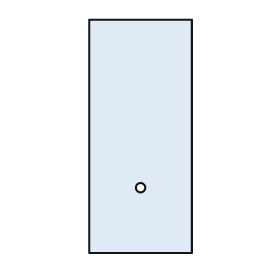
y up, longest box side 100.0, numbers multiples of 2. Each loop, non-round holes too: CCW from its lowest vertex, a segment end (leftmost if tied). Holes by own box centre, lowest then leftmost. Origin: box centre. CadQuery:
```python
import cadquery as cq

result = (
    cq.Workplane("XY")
    .moveTo(-22.0, -50.0)
    .lineTo(22.0, -50.0)
    .lineTo(22.0, 50.0)
    .lineTo(-22.0, 50.0)
    .close()
    .moveTo(0.0, -22.0)
    .circle(2.0)
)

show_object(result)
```